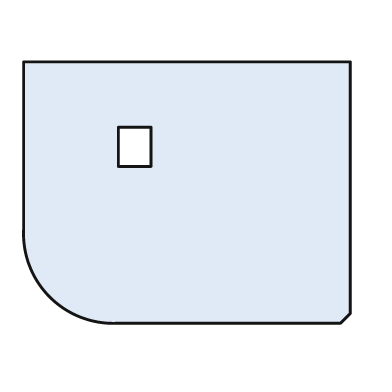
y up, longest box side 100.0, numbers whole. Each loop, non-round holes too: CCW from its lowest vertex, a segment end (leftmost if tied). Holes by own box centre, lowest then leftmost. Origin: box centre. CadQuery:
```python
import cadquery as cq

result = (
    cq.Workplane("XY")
    .moveTo(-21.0, -40.0)
    .lineTo(47.0, -40.0)
    .lineTo(50.0, -37.0)
    .lineTo(50.0, 40.0)
    .lineTo(-50.0, 40.0)
    .lineTo(-50.0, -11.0)
    .threePointArc((-42.0, -32.0), (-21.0, -40.0))
    .close()
    .moveTo(-21.0, 8.0)
    .lineTo(-11.0, 8.0)
    .lineTo(-11.0, 20.0)
    .lineTo(-21.0, 20.0)
    .close()
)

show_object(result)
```